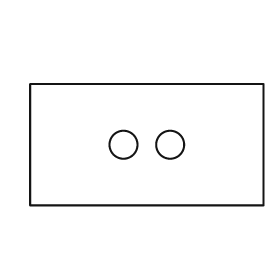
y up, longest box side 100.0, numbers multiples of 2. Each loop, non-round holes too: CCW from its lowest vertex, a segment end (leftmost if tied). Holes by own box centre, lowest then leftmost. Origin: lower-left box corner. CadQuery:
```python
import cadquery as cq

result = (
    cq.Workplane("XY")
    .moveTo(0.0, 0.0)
    .lineTo(100.0, 0.0)
    .lineTo(100.0, 52.0)
    .lineTo(0.0, 52.0)
    .close()
    .moveTo(40.0, 26.0)
    .circle(6.0)
    .moveTo(60.0, 26.0)
    .circle(6.0)
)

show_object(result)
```